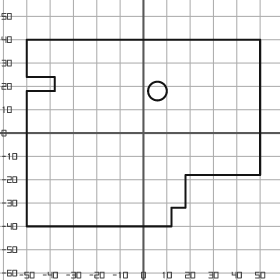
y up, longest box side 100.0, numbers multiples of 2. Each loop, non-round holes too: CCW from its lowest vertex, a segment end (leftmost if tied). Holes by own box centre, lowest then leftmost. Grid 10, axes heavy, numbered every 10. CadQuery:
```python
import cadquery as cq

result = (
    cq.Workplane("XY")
    .moveTo(-50.0, -40.0)
    .lineTo(12.0, -40.0)
    .lineTo(12.0, -32.0)
    .lineTo(18.0, -32.0)
    .lineTo(18.0, -18.0)
    .lineTo(50.0, -18.0)
    .lineTo(50.0, 40.0)
    .lineTo(-50.0, 40.0)
    .lineTo(-50.0, 24.0)
    .lineTo(-38.0, 24.0)
    .lineTo(-38.0, 18.0)
    .lineTo(-50.0, 18.0)
    .close()
    .moveTo(6.0, 18.0)
    .circle(4.0)
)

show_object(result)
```